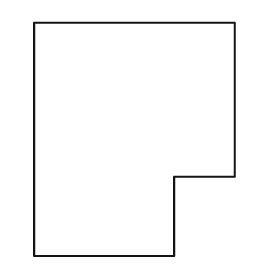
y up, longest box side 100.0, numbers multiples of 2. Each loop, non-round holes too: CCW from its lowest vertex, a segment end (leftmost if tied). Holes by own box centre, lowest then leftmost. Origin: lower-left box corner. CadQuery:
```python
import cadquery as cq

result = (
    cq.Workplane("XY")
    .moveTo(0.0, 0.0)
    .lineTo(60.0, 0.0)
    .lineTo(60.0, 34.0)
    .lineTo(86.0, 34.0)
    .lineTo(86.0, 100.0)
    .lineTo(0.0, 100.0)
    .close()
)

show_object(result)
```